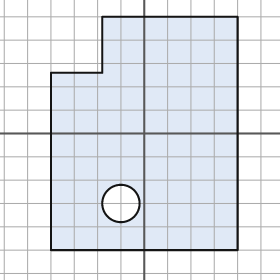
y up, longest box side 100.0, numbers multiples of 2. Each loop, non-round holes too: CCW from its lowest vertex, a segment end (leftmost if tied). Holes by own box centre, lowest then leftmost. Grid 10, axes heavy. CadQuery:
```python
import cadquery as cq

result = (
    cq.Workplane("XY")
    .moveTo(-40.0, -50.0)
    .lineTo(40.0, -50.0)
    .lineTo(40.0, 50.0)
    .lineTo(-18.0, 50.0)
    .lineTo(-18.0, 26.0)
    .lineTo(-40.0, 26.0)
    .close()
    .moveTo(-10.0, -30.0)
    .circle(8.0)
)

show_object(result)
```